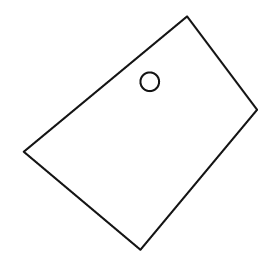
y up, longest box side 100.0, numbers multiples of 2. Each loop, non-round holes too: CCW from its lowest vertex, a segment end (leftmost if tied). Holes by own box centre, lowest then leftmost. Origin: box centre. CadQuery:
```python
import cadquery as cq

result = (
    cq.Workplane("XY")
    .moveTo(0.0, -50.0)
    .lineTo(50.0, 10.0)
    .lineTo(20.0, 50.0)
    .lineTo(-50.0, -8.0)
    .close()
    .moveTo(4.0, 22.0)
    .circle(4.0)
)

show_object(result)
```